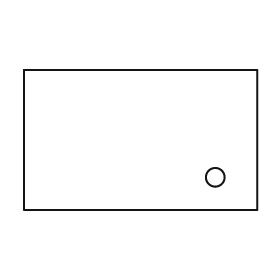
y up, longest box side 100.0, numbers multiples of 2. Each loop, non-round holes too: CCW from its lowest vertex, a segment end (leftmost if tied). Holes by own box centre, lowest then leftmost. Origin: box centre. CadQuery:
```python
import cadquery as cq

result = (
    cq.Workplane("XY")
    .moveTo(-50.0, -30.0)
    .lineTo(50.0, -30.0)
    .lineTo(50.0, 30.0)
    .lineTo(-50.0, 30.0)
    .close()
    .moveTo(32.0, -16.0)
    .circle(4.0)
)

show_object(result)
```